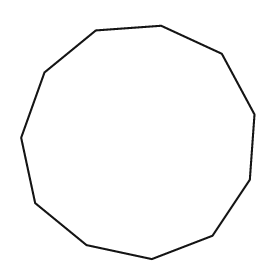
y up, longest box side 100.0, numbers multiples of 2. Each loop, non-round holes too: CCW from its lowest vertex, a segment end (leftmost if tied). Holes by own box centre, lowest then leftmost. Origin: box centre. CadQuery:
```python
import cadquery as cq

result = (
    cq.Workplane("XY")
    .moveTo(6.0, -50.0)
    .lineTo(32.0, -40.0)
    .lineTo(48.0, -16.0)
    .lineTo(50.0, 12.0)
    .lineTo(36.0, 38.0)
    .lineTo(10.0, 50.0)
    .lineTo(-18.0, 48.0)
    .lineTo(-40.0, 30.0)
    .lineTo(-50.0, 2.0)
    .lineTo(-44.0, -26.0)
    .lineTo(-22.0, -44.0)
    .close()
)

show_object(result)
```